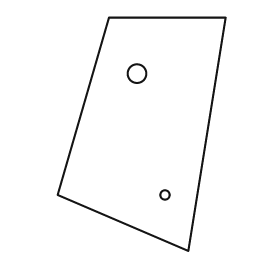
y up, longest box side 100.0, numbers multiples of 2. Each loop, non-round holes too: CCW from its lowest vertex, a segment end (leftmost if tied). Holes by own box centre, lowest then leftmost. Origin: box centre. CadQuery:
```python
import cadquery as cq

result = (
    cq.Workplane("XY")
    .moveTo(20.0, -50.0)
    .lineTo(36.0, 50.0)
    .lineTo(-14.0, 50.0)
    .lineTo(-36.0, -26.0)
    .close()
    .moveTo(10.0, -26.0)
    .circle(2.0)
    .moveTo(-2.0, 26.0)
    .circle(4.0)
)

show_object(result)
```